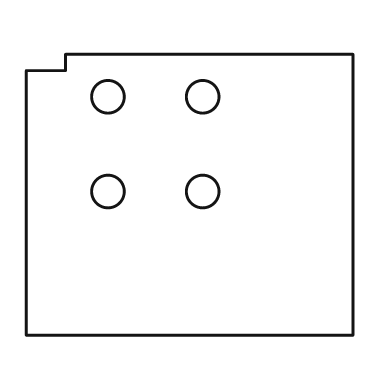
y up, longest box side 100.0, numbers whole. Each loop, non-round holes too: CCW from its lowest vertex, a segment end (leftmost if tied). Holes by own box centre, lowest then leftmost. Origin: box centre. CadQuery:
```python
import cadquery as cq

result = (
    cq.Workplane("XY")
    .moveTo(-50.0, -43.0)
    .lineTo(50.0, -43.0)
    .lineTo(50.0, 43.0)
    .lineTo(-38.0, 43.0)
    .lineTo(-38.0, 38.0)
    .lineTo(-50.0, 38.0)
    .close()
    .moveTo(-25.0, 1.0)
    .circle(5.0)
    .moveTo(4.0, 1.0)
    .circle(5.0)
    .moveTo(-25.0, 30.0)
    .circle(5.0)
    .moveTo(4.0, 30.0)
    .circle(5.0)
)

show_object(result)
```